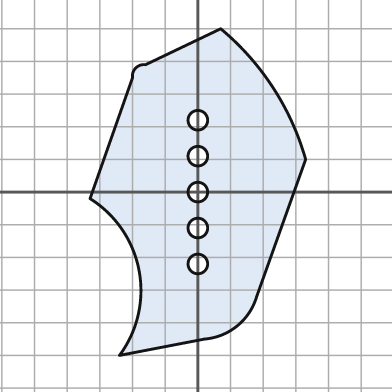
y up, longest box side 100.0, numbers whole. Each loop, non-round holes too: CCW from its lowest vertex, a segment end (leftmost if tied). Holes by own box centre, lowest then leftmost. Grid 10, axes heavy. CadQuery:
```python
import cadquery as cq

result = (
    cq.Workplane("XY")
    .moveTo(-24.0, -50.0)
    .lineTo(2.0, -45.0)
    .threePointArc((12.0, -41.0), (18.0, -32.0))
    .lineTo(33.0, 10.0)
    .threePointArc((23.0, 32.0), (7.0, 50.0))
    .lineTo(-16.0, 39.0)
    .threePointArc((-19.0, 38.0), (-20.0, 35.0))
    .lineTo(-33.0, -2.0)
    .threePointArc((-18.0, -24.0), (-24.0, -50.0))
    .close()
    .moveTo(0.0, -22.0)
    .circle(3.0)
    .moveTo(0.0, -11.0)
    .circle(3.0)
    .moveTo(0.0, 0.0)
    .circle(3.0)
    .moveTo(0.0, 11.0)
    .circle(3.0)
    .moveTo(0.0, 22.0)
    .circle(3.0)
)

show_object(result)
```